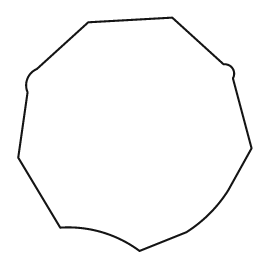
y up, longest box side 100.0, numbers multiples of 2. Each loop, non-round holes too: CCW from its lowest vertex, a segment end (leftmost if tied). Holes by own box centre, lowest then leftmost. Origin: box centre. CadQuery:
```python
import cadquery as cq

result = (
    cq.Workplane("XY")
    .moveTo(2.0, -50.0)
    .lineTo(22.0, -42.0)
    .threePointArc((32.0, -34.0), (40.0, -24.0))
    .lineTo(50.0, -6.0)
    .lineTo(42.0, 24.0)
    .threePointArc((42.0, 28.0), (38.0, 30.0))
    .lineTo(16.0, 50.0)
    .lineTo(-20.0, 48.0)
    .lineTo(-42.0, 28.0)
    .threePointArc((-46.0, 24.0), (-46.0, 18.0))
    .lineTo(-50.0, -10.0)
    .lineTo(-32.0, -40.0)
    .threePointArc((-14.0, -42.0), (2.0, -50.0))
    .close()
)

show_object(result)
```